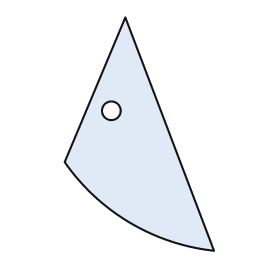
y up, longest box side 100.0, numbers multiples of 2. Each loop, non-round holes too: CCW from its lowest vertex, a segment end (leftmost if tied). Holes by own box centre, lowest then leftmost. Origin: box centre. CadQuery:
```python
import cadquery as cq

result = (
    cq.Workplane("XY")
    .moveTo(32.0, -50.0)
    .lineTo(-6.0, 50.0)
    .lineTo(-32.0, -12.0)
    .threePointArc((-4.0, -38.0), (32.0, -50.0))
    .close()
    .moveTo(-12.0, 10.0)
    .circle(4.0)
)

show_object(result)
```